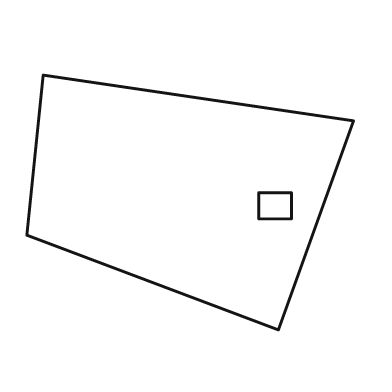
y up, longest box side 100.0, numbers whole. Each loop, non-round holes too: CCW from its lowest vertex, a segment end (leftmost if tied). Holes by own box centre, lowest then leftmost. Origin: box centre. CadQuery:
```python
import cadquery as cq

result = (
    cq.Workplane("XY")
    .moveTo(27.0, -39.0)
    .lineTo(50.0, 25.0)
    .lineTo(-45.0, 39.0)
    .lineTo(-50.0, -10.0)
    .close()
    .moveTo(21.0, -5.0)
    .lineTo(31.0, -5.0)
    .lineTo(31.0, 3.0)
    .lineTo(21.0, 3.0)
    .close()
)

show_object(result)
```